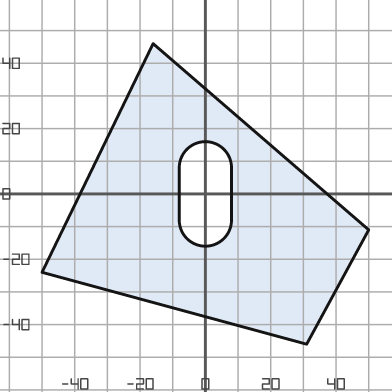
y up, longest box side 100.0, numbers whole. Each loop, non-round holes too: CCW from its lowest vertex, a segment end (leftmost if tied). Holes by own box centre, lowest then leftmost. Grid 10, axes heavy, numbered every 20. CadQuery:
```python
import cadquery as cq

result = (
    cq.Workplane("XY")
    .moveTo(31.0, -46.0)
    .lineTo(50.0, -11.0)
    .lineTo(-16.0, 46.0)
    .lineTo(-50.0, -24.0)
    .close()
    .moveTo(-8.0, -8.0)
    .threePointArc((0.0, -16.0), (8.0, -8.0))
    .lineTo(8.0, 8.0)
    .threePointArc((0.0, 16.0), (-8.0, 8.0))
    .close()
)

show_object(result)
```